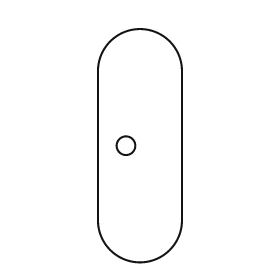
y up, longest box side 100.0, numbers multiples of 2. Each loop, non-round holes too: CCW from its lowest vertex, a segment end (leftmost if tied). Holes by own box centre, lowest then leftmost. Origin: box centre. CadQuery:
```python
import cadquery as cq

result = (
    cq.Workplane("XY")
    .moveTo(-18.0, -32.0)
    .threePointArc((0.0, -50.0), (18.0, -32.0))
    .lineTo(18.0, 32.0)
    .threePointArc((0.0, 50.0), (-18.0, 32.0))
    .close()
    .moveTo(-6.0, 0.0)
    .circle(4.0)
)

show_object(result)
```